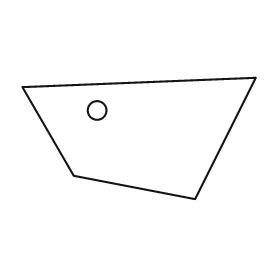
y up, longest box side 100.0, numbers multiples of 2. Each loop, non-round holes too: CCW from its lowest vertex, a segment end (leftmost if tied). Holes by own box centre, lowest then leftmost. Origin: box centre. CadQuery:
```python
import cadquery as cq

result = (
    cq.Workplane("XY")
    .moveTo(24.0, -26.0)
    .lineTo(50.0, 26.0)
    .lineTo(-50.0, 22.0)
    .lineTo(-28.0, -16.0)
    .close()
    .moveTo(-18.0, 12.0)
    .circle(4.0)
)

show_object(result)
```